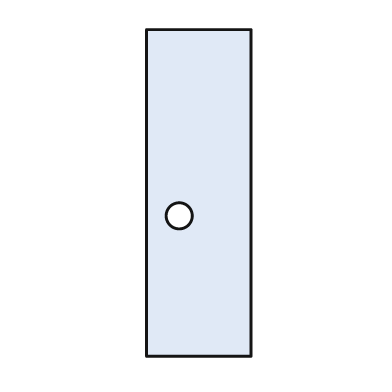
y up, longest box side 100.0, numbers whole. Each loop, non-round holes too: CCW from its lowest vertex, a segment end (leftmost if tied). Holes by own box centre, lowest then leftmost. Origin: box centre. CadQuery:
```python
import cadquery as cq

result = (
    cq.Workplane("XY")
    .moveTo(-16.0, -50.0)
    .lineTo(16.0, -50.0)
    .lineTo(16.0, 50.0)
    .lineTo(-16.0, 50.0)
    .close()
    .moveTo(-6.0, -7.0)
    .circle(4.0)
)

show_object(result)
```